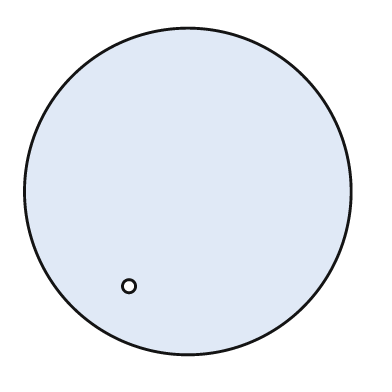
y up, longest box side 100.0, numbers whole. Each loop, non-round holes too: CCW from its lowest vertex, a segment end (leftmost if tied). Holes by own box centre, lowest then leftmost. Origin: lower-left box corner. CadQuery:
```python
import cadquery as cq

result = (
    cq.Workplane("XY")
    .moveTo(50.0, 50.0)
    .circle(50.0)
    .moveTo(32.0, 21.0)
    .circle(2.0)
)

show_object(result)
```